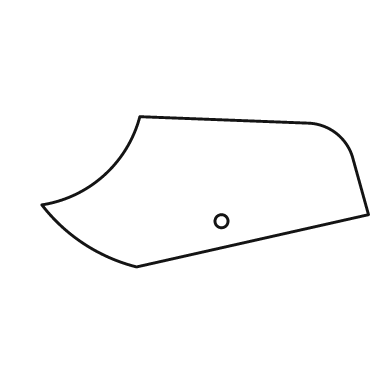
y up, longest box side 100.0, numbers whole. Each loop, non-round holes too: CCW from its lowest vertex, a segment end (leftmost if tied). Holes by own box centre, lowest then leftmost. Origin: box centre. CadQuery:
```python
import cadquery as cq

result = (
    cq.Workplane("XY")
    .moveTo(-21.0, -23.0)
    .lineTo(50.0, -7.0)
    .lineTo(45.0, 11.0)
    .threePointArc((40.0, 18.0), (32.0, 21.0))
    .lineTo(-20.0, 23.0)
    .threePointArc((-31.0, 5.0), (-50.0, -4.0))
    .threePointArc((-37.0, -16.0), (-21.0, -23.0))
    .close()
    .moveTo(5.0, -9.0)
    .circle(2.0)
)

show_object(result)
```